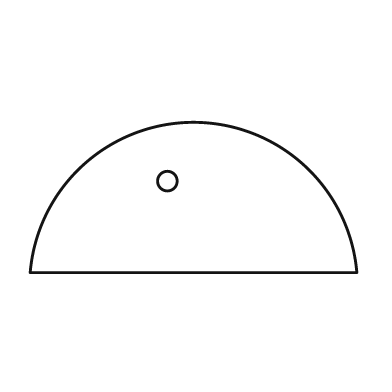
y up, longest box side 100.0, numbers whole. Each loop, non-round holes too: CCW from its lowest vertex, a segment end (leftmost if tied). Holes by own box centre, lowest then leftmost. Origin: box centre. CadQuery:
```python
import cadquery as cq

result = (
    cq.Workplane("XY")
    .moveTo(-50.0, -23.0)
    .lineTo(50.0, -23.0)
    .threePointArc((0.0, 23.0), (-50.0, -23.0))
    .close()
    .moveTo(-8.0, 5.0)
    .circle(3.0)
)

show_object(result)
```